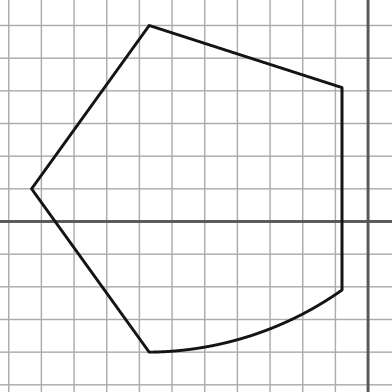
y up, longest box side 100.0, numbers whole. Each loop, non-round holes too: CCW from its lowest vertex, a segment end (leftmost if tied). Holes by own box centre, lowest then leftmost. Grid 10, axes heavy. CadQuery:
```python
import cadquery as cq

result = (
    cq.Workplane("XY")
    .moveTo(-67.0, -40.0)
    .threePointArc((-36.0, -35.0), (-8.0, -21.0))
    .lineTo(-8.0, 41.0)
    .lineTo(-67.0, 60.0)
    .lineTo(-103.0, 10.0)
    .close()
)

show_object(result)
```